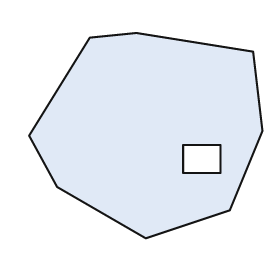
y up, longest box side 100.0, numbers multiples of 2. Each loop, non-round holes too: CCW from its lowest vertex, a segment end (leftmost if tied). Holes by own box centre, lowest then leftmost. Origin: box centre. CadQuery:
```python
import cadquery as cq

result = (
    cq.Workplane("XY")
    .moveTo(0.0, -44.0)
    .lineTo(36.0, -32.0)
    .lineTo(50.0, 2.0)
    .lineTo(46.0, 36.0)
    .lineTo(-4.0, 44.0)
    .lineTo(-24.0, 42.0)
    .lineTo(-50.0, 0.0)
    .lineTo(-38.0, -22.0)
    .close()
    .moveTo(16.0, -16.0)
    .lineTo(32.0, -16.0)
    .lineTo(32.0, -4.0)
    .lineTo(16.0, -4.0)
    .close()
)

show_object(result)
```